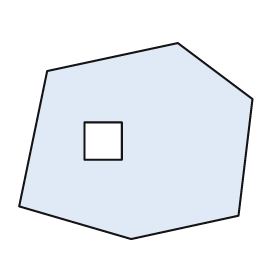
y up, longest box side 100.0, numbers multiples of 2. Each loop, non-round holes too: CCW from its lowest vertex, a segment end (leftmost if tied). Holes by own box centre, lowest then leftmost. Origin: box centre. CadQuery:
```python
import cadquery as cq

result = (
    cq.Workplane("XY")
    .moveTo(-2.0, -42.0)
    .lineTo(44.0, -32.0)
    .lineTo(50.0, 18.0)
    .lineTo(18.0, 42.0)
    .lineTo(-38.0, 30.0)
    .lineTo(-50.0, -28.0)
    .close()
    .moveTo(-22.0, -8.0)
    .lineTo(-6.0, -8.0)
    .lineTo(-6.0, 8.0)
    .lineTo(-22.0, 8.0)
    .close()
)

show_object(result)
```